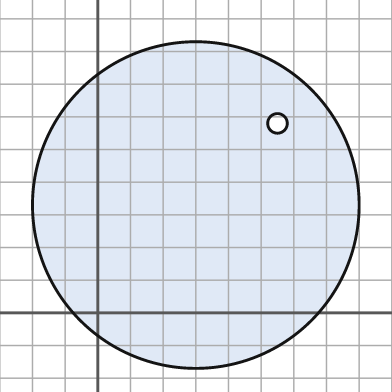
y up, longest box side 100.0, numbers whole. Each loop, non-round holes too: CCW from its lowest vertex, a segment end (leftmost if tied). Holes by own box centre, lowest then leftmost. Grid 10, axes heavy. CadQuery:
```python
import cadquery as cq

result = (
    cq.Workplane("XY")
    .moveTo(30.0, 33.0)
    .circle(50.0)
    .moveTo(55.0, 58.0)
    .circle(3.0)
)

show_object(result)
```